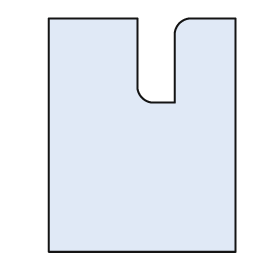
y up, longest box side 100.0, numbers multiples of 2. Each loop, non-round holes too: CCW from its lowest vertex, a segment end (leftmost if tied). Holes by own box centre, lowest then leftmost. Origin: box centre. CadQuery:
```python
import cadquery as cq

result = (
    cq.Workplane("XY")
    .moveTo(-40.0, -50.0)
    .lineTo(40.0, -50.0)
    .lineTo(40.0, 50.0)
    .lineTo(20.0, 50.0)
    .threePointArc((16.0, 48.0), (14.0, 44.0))
    .lineTo(14.0, 14.0)
    .lineTo(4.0, 14.0)
    .threePointArc((0.0, 16.0), (-2.0, 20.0))
    .lineTo(-2.0, 50.0)
    .lineTo(-40.0, 50.0)
    .close()
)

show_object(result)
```